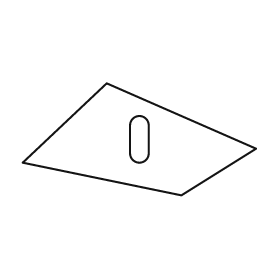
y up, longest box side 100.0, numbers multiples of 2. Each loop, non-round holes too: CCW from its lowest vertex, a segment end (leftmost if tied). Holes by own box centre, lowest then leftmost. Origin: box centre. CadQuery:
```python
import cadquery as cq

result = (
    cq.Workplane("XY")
    .moveTo(18.0, -24.0)
    .lineTo(50.0, -4.0)
    .lineTo(-14.0, 24.0)
    .lineTo(-50.0, -10.0)
    .close()
    .moveTo(-4.0, -6.0)
    .threePointArc((0.0, -10.0), (4.0, -6.0))
    .lineTo(4.0, 6.0)
    .threePointArc((0.0, 10.0), (-4.0, 6.0))
    .close()
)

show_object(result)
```